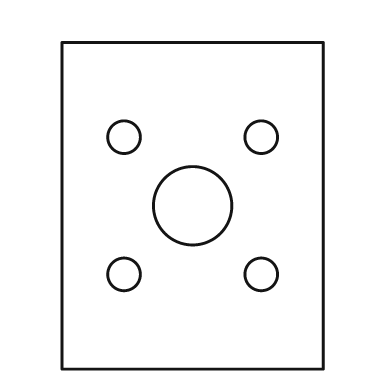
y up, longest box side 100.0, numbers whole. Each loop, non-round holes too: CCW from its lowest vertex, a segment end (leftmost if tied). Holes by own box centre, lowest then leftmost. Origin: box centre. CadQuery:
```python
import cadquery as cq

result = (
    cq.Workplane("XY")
    .moveTo(-40.0, -50.0)
    .lineTo(40.0, -50.0)
    .lineTo(40.0, 50.0)
    .lineTo(-40.0, 50.0)
    .close()
    .moveTo(-21.0, -21.0)
    .circle(5.0)
    .moveTo(21.0, -21.0)
    .circle(5.0)
    .moveTo(0.0, 0.0)
    .circle(12.0)
    .moveTo(-21.0, 21.0)
    .circle(5.0)
    .moveTo(21.0, 21.0)
    .circle(5.0)
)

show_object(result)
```